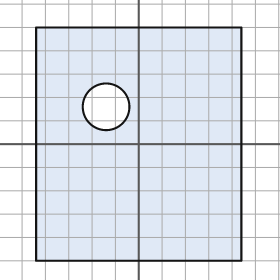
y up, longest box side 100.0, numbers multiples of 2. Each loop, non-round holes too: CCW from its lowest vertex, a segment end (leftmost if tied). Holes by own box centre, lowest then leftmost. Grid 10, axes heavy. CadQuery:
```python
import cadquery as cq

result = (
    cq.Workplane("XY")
    .moveTo(-44.0, -50.0)
    .lineTo(44.0, -50.0)
    .lineTo(44.0, 50.0)
    .lineTo(-44.0, 50.0)
    .close()
    .moveTo(-14.0, 16.0)
    .circle(10.0)
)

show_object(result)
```